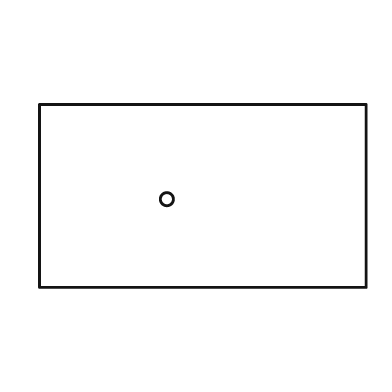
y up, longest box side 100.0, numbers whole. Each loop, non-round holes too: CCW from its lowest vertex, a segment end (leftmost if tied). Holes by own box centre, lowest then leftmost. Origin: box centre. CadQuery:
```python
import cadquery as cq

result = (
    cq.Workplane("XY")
    .moveTo(-50.0, -28.0)
    .lineTo(50.0, -28.0)
    .lineTo(50.0, 28.0)
    .lineTo(-50.0, 28.0)
    .close()
    .moveTo(-11.0, -1.0)
    .circle(2.0)
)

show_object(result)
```